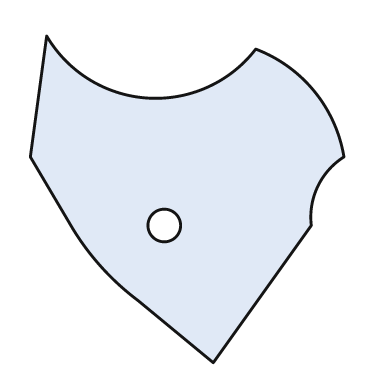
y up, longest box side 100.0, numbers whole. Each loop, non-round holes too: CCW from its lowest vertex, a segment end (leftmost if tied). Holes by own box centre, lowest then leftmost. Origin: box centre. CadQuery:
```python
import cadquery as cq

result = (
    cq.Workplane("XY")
    .moveTo(8.0, -50.0)
    .lineTo(38.0, -8.0)
    .threePointArc((40.0, 4.0), (48.0, 13.0))
    .threePointArc((39.0, 33.0), (21.0, 46.0))
    .threePointArc((-12.0, 31.0), (-43.0, 50.0))
    .lineTo(-48.0, 13.0)
    .lineTo(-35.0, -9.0)
    .threePointArc((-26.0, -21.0), (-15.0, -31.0))
    .close()
    .moveTo(-7.0, -8.0)
    .circle(5.0)
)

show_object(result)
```